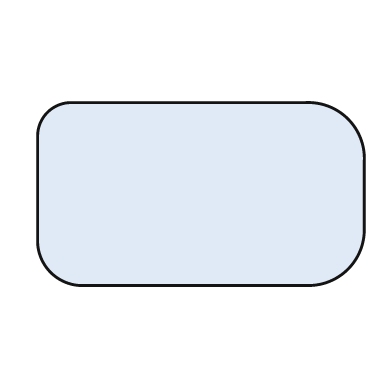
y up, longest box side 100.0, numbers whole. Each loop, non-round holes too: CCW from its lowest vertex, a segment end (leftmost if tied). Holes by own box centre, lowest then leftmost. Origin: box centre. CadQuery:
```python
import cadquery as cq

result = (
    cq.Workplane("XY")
    .moveTo(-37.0, -28.0)
    .lineTo(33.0, -28.0)
    .threePointArc((45.0, -23.0), (50.0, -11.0))
    .lineTo(50.0, 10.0)
    .threePointArc((45.0, 23.0), (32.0, 28.0))
    .lineTo(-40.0, 28.0)
    .threePointArc((-47.0, 25.0), (-50.0, 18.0))
    .lineTo(-50.0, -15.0)
    .threePointArc((-46.0, -24.0), (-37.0, -28.0))
    .close()
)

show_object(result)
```